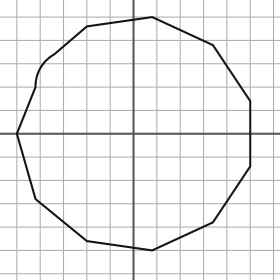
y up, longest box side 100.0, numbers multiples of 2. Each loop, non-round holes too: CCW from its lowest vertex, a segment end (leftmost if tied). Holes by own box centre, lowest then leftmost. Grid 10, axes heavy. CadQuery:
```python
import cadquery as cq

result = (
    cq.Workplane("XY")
    .moveTo(8.0, -50.0)
    .lineTo(34.0, -38.0)
    .lineTo(50.0, -14.0)
    .lineTo(50.0, 14.0)
    .lineTo(34.0, 38.0)
    .lineTo(8.0, 50.0)
    .lineTo(-20.0, 46.0)
    .lineTo(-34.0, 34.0)
    .threePointArc((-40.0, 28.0), (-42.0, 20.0))
    .lineTo(-50.0, 0.0)
    .lineTo(-42.0, -28.0)
    .lineTo(-20.0, -46.0)
    .close()
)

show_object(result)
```